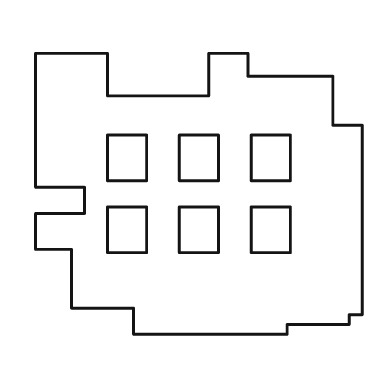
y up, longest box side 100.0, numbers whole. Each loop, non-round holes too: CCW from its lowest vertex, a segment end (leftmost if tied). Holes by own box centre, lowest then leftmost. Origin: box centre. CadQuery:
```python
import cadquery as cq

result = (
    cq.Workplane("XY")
    .moveTo(-20.0, -43.0)
    .lineTo(27.0, -43.0)
    .lineTo(27.0, -40.0)
    .lineTo(46.0, -40.0)
    .lineTo(46.0, -37.0)
    .lineTo(50.0, -37.0)
    .lineTo(50.0, 21.0)
    .lineTo(41.0, 21.0)
    .lineTo(41.0, 36.0)
    .lineTo(15.0, 36.0)
    .lineTo(15.0, 43.0)
    .lineTo(3.0, 43.0)
    .lineTo(3.0, 30.0)
    .lineTo(-28.0, 30.0)
    .lineTo(-28.0, 43.0)
    .lineTo(-50.0, 43.0)
    .lineTo(-50.0, 2.0)
    .lineTo(-35.0, 2.0)
    .lineTo(-35.0, -6.0)
    .lineTo(-50.0, -6.0)
    .lineTo(-50.0, -17.0)
    .lineTo(-39.0, -17.0)
    .lineTo(-39.0, -35.0)
    .lineTo(-20.0, -35.0)
    .close()
    .moveTo(-28.0, -18.0)
    .lineTo(-16.0, -18.0)
    .lineTo(-16.0, -4.0)
    .lineTo(-28.0, -4.0)
    .close()
    .moveTo(-6.0, -18.0)
    .lineTo(6.0, -18.0)
    .lineTo(6.0, -4.0)
    .lineTo(-6.0, -4.0)
    .close()
    .moveTo(16.0, -18.0)
    .lineTo(28.0, -18.0)
    .lineTo(28.0, -4.0)
    .lineTo(16.0, -4.0)
    .close()
    .moveTo(-28.0, 4.0)
    .lineTo(-16.0, 4.0)
    .lineTo(-16.0, 18.0)
    .lineTo(-28.0, 18.0)
    .close()
    .moveTo(-6.0, 4.0)
    .lineTo(6.0, 4.0)
    .lineTo(6.0, 18.0)
    .lineTo(-6.0, 18.0)
    .close()
    .moveTo(16.0, 4.0)
    .lineTo(28.0, 4.0)
    .lineTo(28.0, 18.0)
    .lineTo(16.0, 18.0)
    .close()
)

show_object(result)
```